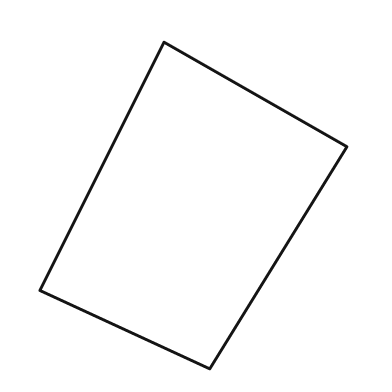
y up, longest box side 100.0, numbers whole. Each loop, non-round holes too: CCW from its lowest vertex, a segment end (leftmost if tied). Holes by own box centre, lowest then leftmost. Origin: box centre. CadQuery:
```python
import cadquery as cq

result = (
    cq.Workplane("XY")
    .moveTo(5.0, -50.0)
    .lineTo(47.0, 18.0)
    .lineTo(-9.0, 50.0)
    .lineTo(-47.0, -26.0)
    .close()
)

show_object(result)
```